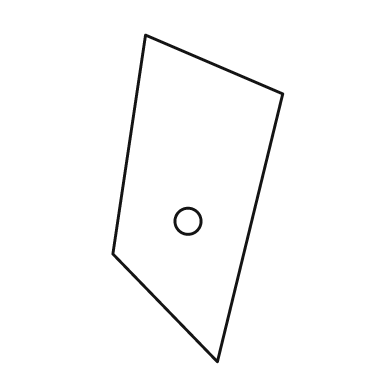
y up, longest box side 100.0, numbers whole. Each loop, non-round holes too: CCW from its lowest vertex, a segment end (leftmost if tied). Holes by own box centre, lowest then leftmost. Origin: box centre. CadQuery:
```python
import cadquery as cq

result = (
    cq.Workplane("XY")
    .moveTo(6.0, -50.0)
    .lineTo(26.0, 32.0)
    .lineTo(-16.0, 50.0)
    .lineTo(-26.0, -17.0)
    .close()
    .moveTo(-3.0, -7.0)
    .circle(4.0)
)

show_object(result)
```